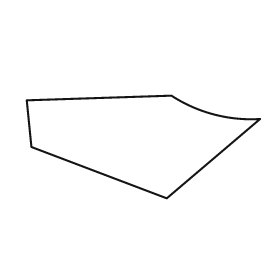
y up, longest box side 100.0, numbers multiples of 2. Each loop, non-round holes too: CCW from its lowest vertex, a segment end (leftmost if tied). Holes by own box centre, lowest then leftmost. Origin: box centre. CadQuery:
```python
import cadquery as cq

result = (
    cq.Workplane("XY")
    .moveTo(10.0, -22.0)
    .lineTo(50.0, 12.0)
    .threePointArc((30.0, 14.0), (12.0, 22.0))
    .lineTo(-50.0, 20.0)
    .lineTo(-48.0, 0.0)
    .close()
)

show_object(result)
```